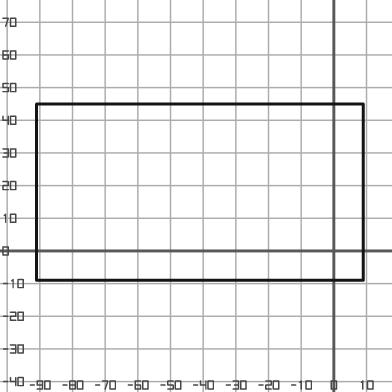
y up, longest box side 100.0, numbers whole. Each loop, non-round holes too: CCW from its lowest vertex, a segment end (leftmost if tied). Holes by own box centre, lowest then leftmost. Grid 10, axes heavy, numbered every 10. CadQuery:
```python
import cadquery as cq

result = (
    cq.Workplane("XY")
    .moveTo(-91.0, -9.0)
    .lineTo(9.0, -9.0)
    .lineTo(9.0, 45.0)
    .lineTo(-91.0, 45.0)
    .close()
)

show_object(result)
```